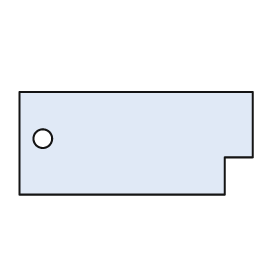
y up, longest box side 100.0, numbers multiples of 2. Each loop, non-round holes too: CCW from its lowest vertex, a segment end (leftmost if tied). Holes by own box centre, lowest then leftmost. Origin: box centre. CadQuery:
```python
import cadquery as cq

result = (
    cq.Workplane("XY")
    .moveTo(-50.0, -22.0)
    .lineTo(38.0, -22.0)
    .lineTo(38.0, -6.0)
    .lineTo(50.0, -6.0)
    .lineTo(50.0, 22.0)
    .lineTo(-50.0, 22.0)
    .close()
    .moveTo(-40.0, 2.0)
    .circle(4.0)
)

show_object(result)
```